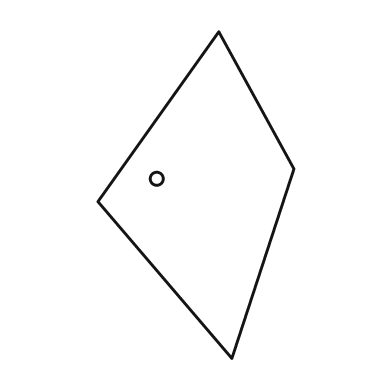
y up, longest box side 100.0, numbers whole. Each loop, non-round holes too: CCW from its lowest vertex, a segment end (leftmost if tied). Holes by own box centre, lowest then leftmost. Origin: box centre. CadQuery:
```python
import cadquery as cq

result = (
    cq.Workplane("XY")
    .moveTo(11.0, -50.0)
    .lineTo(30.0, 8.0)
    .lineTo(7.0, 50.0)
    .lineTo(-30.0, -2.0)
    .close()
    .moveTo(-12.0, 5.0)
    .circle(2.0)
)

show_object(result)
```